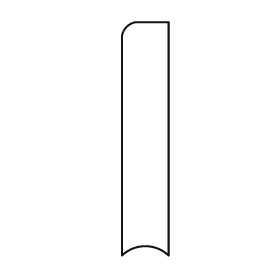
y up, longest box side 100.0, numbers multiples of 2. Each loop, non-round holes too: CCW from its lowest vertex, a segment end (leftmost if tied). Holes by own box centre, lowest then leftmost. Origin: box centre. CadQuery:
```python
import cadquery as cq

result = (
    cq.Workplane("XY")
    .moveTo(-10.0, -50.0)
    .threePointArc((0.0, -46.0), (10.0, -50.0))
    .lineTo(10.0, 50.0)
    .lineTo(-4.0, 50.0)
    .threePointArc((-8.0, 48.0), (-10.0, 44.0))
    .close()
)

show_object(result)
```